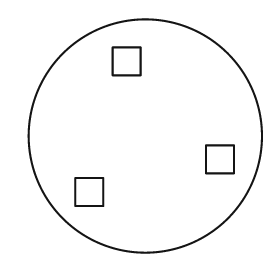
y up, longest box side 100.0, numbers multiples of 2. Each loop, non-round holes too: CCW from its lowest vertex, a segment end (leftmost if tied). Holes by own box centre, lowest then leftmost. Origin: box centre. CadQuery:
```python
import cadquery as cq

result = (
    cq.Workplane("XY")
    .moveTo(0.0, 0.0)
    .circle(50.0)
    .moveTo(-30.0, -30.0)
    .lineTo(-18.0, -30.0)
    .lineTo(-18.0, -18.0)
    .lineTo(-30.0, -18.0)
    .close()
    .moveTo(26.0, -16.0)
    .lineTo(38.0, -16.0)
    .lineTo(38.0, -4.0)
    .lineTo(26.0, -4.0)
    .close()
    .moveTo(-14.0, 26.0)
    .lineTo(-2.0, 26.0)
    .lineTo(-2.0, 38.0)
    .lineTo(-14.0, 38.0)
    .close()
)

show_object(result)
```